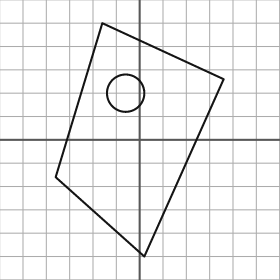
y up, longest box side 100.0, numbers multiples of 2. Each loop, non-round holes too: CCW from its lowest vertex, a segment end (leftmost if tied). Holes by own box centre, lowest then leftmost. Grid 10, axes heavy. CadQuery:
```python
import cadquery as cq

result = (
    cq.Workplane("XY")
    .moveTo(2.0, -50.0)
    .lineTo(36.0, 26.0)
    .lineTo(-16.0, 50.0)
    .lineTo(-36.0, -16.0)
    .close()
    .moveTo(-6.0, 20.0)
    .circle(8.0)
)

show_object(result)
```